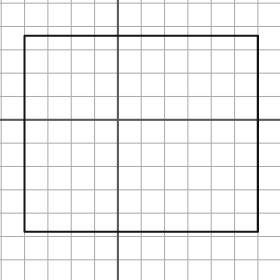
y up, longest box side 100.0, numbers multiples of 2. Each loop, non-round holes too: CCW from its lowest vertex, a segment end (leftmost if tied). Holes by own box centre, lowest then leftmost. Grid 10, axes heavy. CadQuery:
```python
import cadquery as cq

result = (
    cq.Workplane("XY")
    .moveTo(-40.0, -48.0)
    .lineTo(60.0, -48.0)
    .lineTo(60.0, 36.0)
    .lineTo(-40.0, 36.0)
    .close()
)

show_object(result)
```